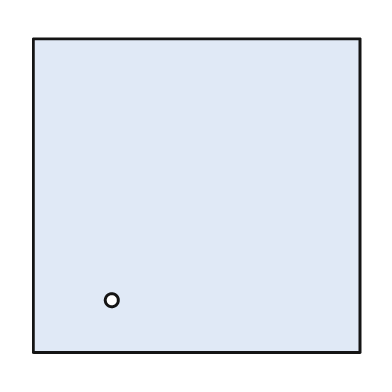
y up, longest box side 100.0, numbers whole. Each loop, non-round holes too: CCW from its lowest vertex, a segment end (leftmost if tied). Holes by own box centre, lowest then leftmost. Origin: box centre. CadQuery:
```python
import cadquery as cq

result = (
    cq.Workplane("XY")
    .moveTo(-50.0, -48.0)
    .lineTo(50.0, -48.0)
    .lineTo(50.0, 48.0)
    .lineTo(-50.0, 48.0)
    .close()
    .moveTo(-26.0, -32.0)
    .circle(2.0)
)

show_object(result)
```